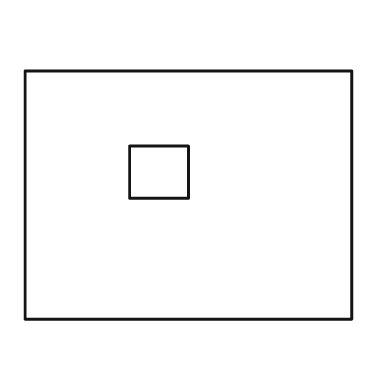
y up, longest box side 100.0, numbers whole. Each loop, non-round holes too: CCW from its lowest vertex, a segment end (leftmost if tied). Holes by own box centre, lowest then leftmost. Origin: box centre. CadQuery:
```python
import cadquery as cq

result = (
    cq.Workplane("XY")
    .moveTo(-50.0, -38.0)
    .lineTo(50.0, -38.0)
    .lineTo(50.0, 38.0)
    .lineTo(-50.0, 38.0)
    .close()
    .moveTo(-18.0, -1.0)
    .lineTo(0.0, -1.0)
    .lineTo(0.0, 15.0)
    .lineTo(-18.0, 15.0)
    .close()
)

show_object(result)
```